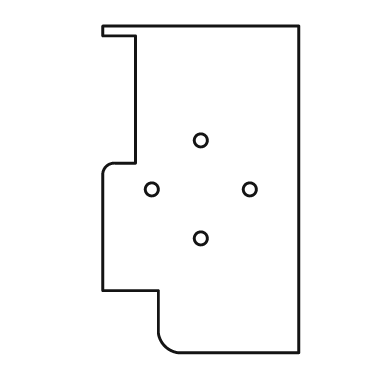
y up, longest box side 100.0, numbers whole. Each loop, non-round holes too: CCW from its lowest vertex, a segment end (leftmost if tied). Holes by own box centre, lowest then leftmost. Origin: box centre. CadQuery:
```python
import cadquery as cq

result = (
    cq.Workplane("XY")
    .moveTo(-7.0, -50.0)
    .lineTo(30.0, -50.0)
    .lineTo(30.0, 50.0)
    .lineTo(-30.0, 50.0)
    .lineTo(-30.0, 47.0)
    .lineTo(-20.0, 47.0)
    .lineTo(-20.0, 8.0)
    .lineTo(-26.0, 8.0)
    .threePointArc((-29.0, 7.0), (-30.0, 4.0))
    .lineTo(-30.0, -31.0)
    .lineTo(-13.0, -31.0)
    .lineTo(-13.0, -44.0)
    .threePointArc((-11.0, -48.0), (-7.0, -50.0))
    .close()
    .moveTo(0.0, -15.0)
    .circle(2.0)
    .moveTo(-15.0, 0.0)
    .circle(2.0)
    .moveTo(15.0, 0.0)
    .circle(2.0)
    .moveTo(0.0, 15.0)
    .circle(2.0)
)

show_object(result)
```